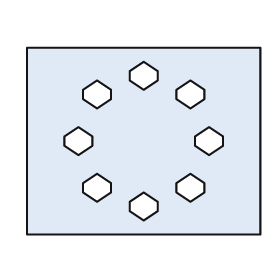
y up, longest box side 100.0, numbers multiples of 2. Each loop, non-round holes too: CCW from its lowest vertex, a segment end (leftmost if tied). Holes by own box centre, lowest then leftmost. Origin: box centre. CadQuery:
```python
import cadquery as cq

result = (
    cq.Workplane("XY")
    .moveTo(-50.0, -40.0)
    .lineTo(50.0, -40.0)
    .lineTo(50.0, 40.0)
    .lineTo(-50.0, 40.0)
    .close()
    .moveTo(0.0, -34.0)
    .lineTo(6.0, -30.0)
    .lineTo(6.0, -26.0)
    .lineTo(0.0, -22.0)
    .lineTo(-6.0, -26.0)
    .lineTo(-6.0, -30.0)
    .close()
    .moveTo(-20.0, -26.0)
    .lineTo(-14.0, -22.0)
    .lineTo(-14.0, -18.0)
    .lineTo(-20.0, -14.0)
    .lineTo(-26.0, -18.0)
    .lineTo(-26.0, -22.0)
    .close()
    .moveTo(20.0, -26.0)
    .lineTo(26.0, -22.0)
    .lineTo(26.0, -18.0)
    .lineTo(20.0, -14.0)
    .lineTo(14.0, -18.0)
    .lineTo(14.0, -22.0)
    .close()
    .moveTo(-28.0, -6.0)
    .lineTo(-22.0, -2.0)
    .lineTo(-22.0, 2.0)
    .lineTo(-28.0, 6.0)
    .lineTo(-34.0, 2.0)
    .lineTo(-34.0, -2.0)
    .close()
    .moveTo(28.0, -6.0)
    .lineTo(34.0, -2.0)
    .lineTo(34.0, 2.0)
    .lineTo(28.0, 6.0)
    .lineTo(22.0, 2.0)
    .lineTo(22.0, -2.0)
    .close()
    .moveTo(-20.0, 14.0)
    .lineTo(-14.0, 18.0)
    .lineTo(-14.0, 22.0)
    .lineTo(-20.0, 26.0)
    .lineTo(-26.0, 22.0)
    .lineTo(-26.0, 18.0)
    .close()
    .moveTo(20.0, 14.0)
    .lineTo(26.0, 18.0)
    .lineTo(26.0, 22.0)
    .lineTo(20.0, 26.0)
    .lineTo(14.0, 22.0)
    .lineTo(14.0, 18.0)
    .close()
    .moveTo(0.0, 22.0)
    .lineTo(6.0, 26.0)
    .lineTo(6.0, 30.0)
    .lineTo(0.0, 34.0)
    .lineTo(-6.0, 30.0)
    .lineTo(-6.0, 26.0)
    .close()
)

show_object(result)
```